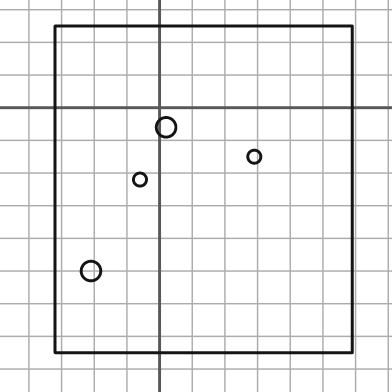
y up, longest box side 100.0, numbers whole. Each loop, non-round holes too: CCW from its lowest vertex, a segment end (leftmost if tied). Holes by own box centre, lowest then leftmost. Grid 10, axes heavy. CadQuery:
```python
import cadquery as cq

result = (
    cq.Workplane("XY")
    .moveTo(-32.0, -75.0)
    .lineTo(59.0, -75.0)
    .lineTo(59.0, 25.0)
    .lineTo(-32.0, 25.0)
    .close()
    .moveTo(-21.0, -50.0)
    .circle(3.0)
    .moveTo(-6.0, -22.0)
    .circle(2.0)
    .moveTo(29.0, -15.0)
    .circle(2.0)
    .moveTo(2.0, -6.0)
    .circle(3.0)
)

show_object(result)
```